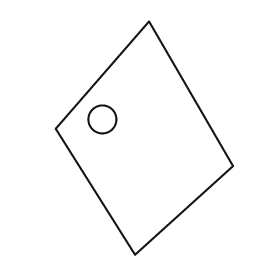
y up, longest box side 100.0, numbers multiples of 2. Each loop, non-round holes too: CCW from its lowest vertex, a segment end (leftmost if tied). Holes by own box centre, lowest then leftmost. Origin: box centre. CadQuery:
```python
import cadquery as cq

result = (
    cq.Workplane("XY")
    .moveTo(-4.0, -50.0)
    .lineTo(38.0, -12.0)
    .lineTo(2.0, 50.0)
    .lineTo(-38.0, 4.0)
    .close()
    .moveTo(-18.0, 8.0)
    .circle(6.0)
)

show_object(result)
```